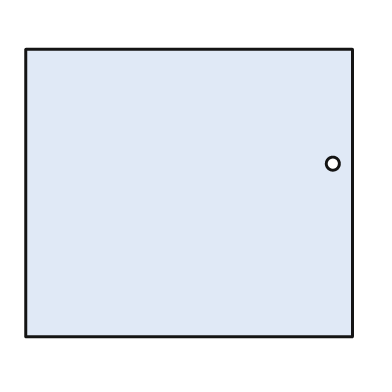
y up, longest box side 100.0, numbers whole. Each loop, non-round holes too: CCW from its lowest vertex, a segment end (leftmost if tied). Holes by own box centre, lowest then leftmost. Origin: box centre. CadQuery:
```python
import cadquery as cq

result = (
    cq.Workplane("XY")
    .moveTo(-50.0, -44.0)
    .lineTo(50.0, -44.0)
    .lineTo(50.0, 44.0)
    .lineTo(-50.0, 44.0)
    .close()
    .moveTo(44.0, 9.0)
    .circle(2.0)
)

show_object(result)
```